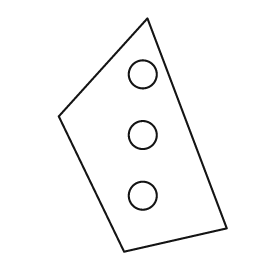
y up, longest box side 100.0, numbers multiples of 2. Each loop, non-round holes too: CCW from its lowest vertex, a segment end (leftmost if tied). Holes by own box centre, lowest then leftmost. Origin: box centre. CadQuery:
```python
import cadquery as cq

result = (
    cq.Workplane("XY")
    .moveTo(-8.0, -50.0)
    .lineTo(36.0, -40.0)
    .lineTo(2.0, 50.0)
    .lineTo(-36.0, 8.0)
    .close()
    .moveTo(0.0, -26.0)
    .circle(6.0)
    .moveTo(0.0, 0.0)
    .circle(6.0)
    .moveTo(0.0, 26.0)
    .circle(6.0)
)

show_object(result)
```